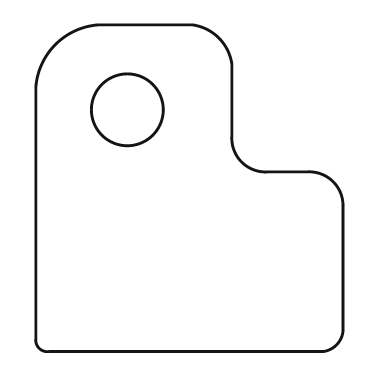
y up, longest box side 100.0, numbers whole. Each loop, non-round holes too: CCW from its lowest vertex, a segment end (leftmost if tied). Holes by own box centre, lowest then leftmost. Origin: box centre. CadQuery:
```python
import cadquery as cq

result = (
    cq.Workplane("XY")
    .moveTo(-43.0, -50.0)
    .lineTo(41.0, -50.0)
    .threePointArc((45.0, -48.0), (47.0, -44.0))
    .lineTo(47.0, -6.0)
    .threePointArc((44.0, 2.0), (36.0, 5.0))
    .lineTo(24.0, 5.0)
    .threePointArc((16.0, 8.0), (13.0, 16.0))
    .lineTo(13.0, 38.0)
    .threePointArc((9.0, 46.0), (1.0, 50.0))
    .lineTo(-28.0, 50.0)
    .threePointArc((-41.0, 44.0), (-47.0, 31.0))
    .lineTo(-47.0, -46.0)
    .threePointArc((-46.0, -49.0), (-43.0, -50.0))
    .close()
    .moveTo(-19.0, 24.0)
    .circle(11.0)
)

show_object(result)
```